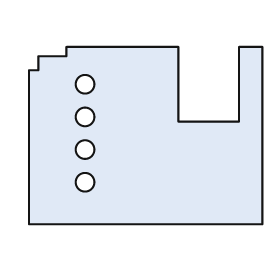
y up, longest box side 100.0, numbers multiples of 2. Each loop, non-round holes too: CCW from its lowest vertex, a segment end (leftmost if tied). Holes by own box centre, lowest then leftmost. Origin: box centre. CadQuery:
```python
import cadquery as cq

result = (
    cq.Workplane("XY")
    .moveTo(-50.0, -38.0)
    .lineTo(50.0, -38.0)
    .lineTo(50.0, 38.0)
    .lineTo(40.0, 38.0)
    .lineTo(40.0, 6.0)
    .lineTo(14.0, 6.0)
    .lineTo(14.0, 38.0)
    .lineTo(-34.0, 38.0)
    .lineTo(-34.0, 34.0)
    .lineTo(-46.0, 34.0)
    .lineTo(-46.0, 28.0)
    .lineTo(-50.0, 28.0)
    .close()
    .moveTo(-26.0, -20.0)
    .circle(4.0)
    .moveTo(-26.0, -6.0)
    .circle(4.0)
    .moveTo(-26.0, 8.0)
    .circle(4.0)
    .moveTo(-26.0, 22.0)
    .circle(4.0)
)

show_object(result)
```